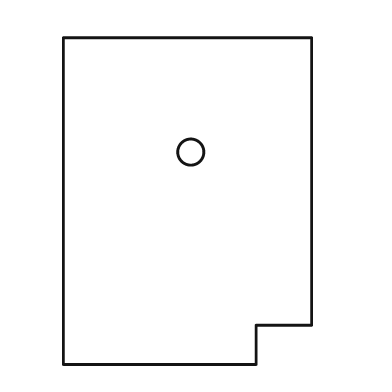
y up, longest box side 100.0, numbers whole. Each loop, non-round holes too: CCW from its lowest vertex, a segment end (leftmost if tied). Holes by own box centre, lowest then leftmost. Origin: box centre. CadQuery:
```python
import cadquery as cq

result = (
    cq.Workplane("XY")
    .moveTo(-38.0, -50.0)
    .lineTo(21.0, -50.0)
    .lineTo(21.0, -38.0)
    .lineTo(38.0, -38.0)
    .lineTo(38.0, 50.0)
    .lineTo(-38.0, 50.0)
    .close()
    .moveTo(1.0, 15.0)
    .circle(4.0)
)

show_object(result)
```